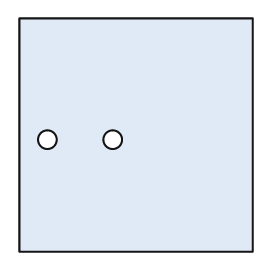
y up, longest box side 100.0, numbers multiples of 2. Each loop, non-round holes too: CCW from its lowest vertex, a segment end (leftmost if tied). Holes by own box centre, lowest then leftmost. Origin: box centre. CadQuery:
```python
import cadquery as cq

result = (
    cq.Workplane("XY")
    .moveTo(-50.0, -50.0)
    .lineTo(50.0, -50.0)
    .lineTo(50.0, 50.0)
    .lineTo(-50.0, 50.0)
    .close()
    .moveTo(-38.0, -2.0)
    .circle(4.0)
    .moveTo(-10.0, -2.0)
    .circle(4.0)
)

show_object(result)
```